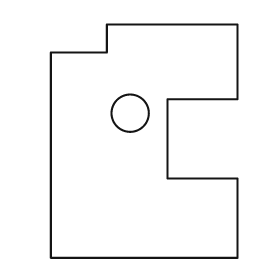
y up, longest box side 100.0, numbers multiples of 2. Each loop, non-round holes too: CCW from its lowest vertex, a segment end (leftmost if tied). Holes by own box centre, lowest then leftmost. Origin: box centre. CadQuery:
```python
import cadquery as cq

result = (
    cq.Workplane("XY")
    .moveTo(-40.0, -50.0)
    .lineTo(40.0, -50.0)
    .lineTo(40.0, -16.0)
    .lineTo(10.0, -16.0)
    .lineTo(10.0, 18.0)
    .lineTo(40.0, 18.0)
    .lineTo(40.0, 50.0)
    .lineTo(-16.0, 50.0)
    .lineTo(-16.0, 38.0)
    .lineTo(-40.0, 38.0)
    .close()
    .moveTo(-6.0, 12.0)
    .circle(8.0)
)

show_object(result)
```